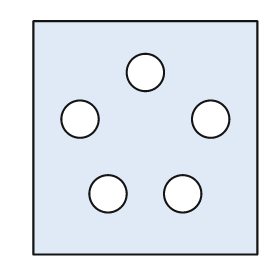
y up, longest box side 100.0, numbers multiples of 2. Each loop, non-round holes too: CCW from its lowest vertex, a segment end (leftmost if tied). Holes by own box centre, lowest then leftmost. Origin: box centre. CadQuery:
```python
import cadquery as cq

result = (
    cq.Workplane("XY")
    .moveTo(-48.0, -50.0)
    .lineTo(48.0, -50.0)
    .lineTo(48.0, 50.0)
    .lineTo(-48.0, 50.0)
    .close()
    .moveTo(-16.0, -24.0)
    .circle(8.0)
    .moveTo(16.0, -24.0)
    .circle(8.0)
    .moveTo(-28.0, 8.0)
    .circle(8.0)
    .moveTo(28.0, 8.0)
    .circle(8.0)
    .moveTo(0.0, 28.0)
    .circle(8.0)
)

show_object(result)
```